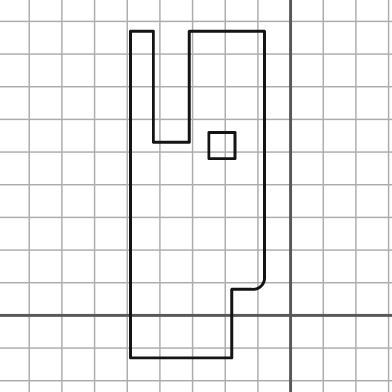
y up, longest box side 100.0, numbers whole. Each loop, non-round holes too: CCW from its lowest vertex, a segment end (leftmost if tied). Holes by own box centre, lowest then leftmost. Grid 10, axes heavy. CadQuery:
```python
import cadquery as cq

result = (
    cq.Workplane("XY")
    .moveTo(-49.0, -13.0)
    .lineTo(-18.0, -13.0)
    .lineTo(-18.0, 8.0)
    .lineTo(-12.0, 8.0)
    .threePointArc((-9.0, 9.0), (-8.0, 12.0))
    .lineTo(-8.0, 87.0)
    .lineTo(-31.0, 87.0)
    .lineTo(-31.0, 53.0)
    .lineTo(-42.0, 53.0)
    .lineTo(-42.0, 87.0)
    .lineTo(-49.0, 87.0)
    .close()
    .moveTo(-25.0, 48.0)
    .lineTo(-17.0, 48.0)
    .lineTo(-17.0, 56.0)
    .lineTo(-25.0, 56.0)
    .close()
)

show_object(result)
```